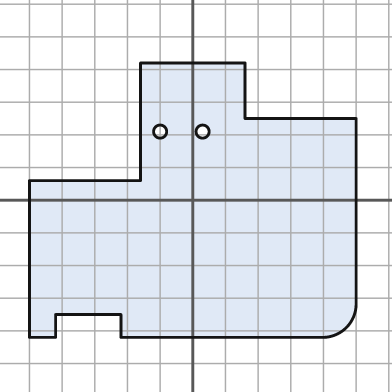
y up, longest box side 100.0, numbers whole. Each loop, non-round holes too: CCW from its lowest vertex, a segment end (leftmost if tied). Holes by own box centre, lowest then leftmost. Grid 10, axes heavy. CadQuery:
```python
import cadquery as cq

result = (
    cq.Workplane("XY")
    .moveTo(-50.0, -42.0)
    .lineTo(-42.0, -42.0)
    .lineTo(-42.0, -35.0)
    .lineTo(-22.0, -35.0)
    .lineTo(-22.0, -42.0)
    .lineTo(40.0, -42.0)
    .threePointArc((47.0, -39.0), (50.0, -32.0))
    .lineTo(50.0, 25.0)
    .lineTo(16.0, 25.0)
    .lineTo(16.0, 42.0)
    .lineTo(-16.0, 42.0)
    .lineTo(-16.0, 6.0)
    .lineTo(-50.0, 6.0)
    .close()
    .moveTo(-10.0, 21.0)
    .circle(2.0)
    .moveTo(3.0, 21.0)
    .circle(2.0)
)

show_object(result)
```